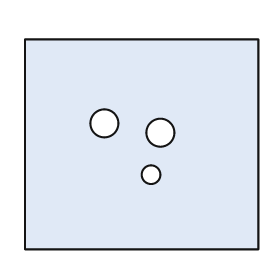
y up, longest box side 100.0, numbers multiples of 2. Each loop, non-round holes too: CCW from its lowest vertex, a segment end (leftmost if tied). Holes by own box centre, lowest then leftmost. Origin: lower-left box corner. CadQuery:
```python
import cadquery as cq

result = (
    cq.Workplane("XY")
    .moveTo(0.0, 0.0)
    .lineTo(100.0, 0.0)
    .lineTo(100.0, 90.0)
    .lineTo(0.0, 90.0)
    .close()
    .moveTo(54.0, 32.0)
    .circle(4.0)
    .moveTo(58.0, 50.0)
    .circle(6.0)
    .moveTo(34.0, 54.0)
    .circle(6.0)
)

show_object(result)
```